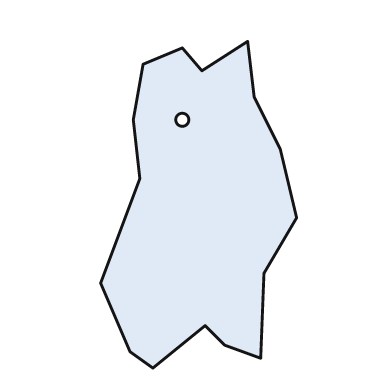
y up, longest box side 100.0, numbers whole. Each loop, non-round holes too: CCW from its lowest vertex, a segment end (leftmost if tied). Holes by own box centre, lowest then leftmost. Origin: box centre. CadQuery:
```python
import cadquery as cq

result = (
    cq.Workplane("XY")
    .moveTo(-14.0, -50.0)
    .lineTo(2.0, -37.0)
    .lineTo(8.0, -43.0)
    .lineTo(19.0, -47.0)
    .lineTo(20.0, -21.0)
    .lineTo(30.0, -4.0)
    .lineTo(25.0, 17.0)
    .lineTo(17.0, 33.0)
    .lineTo(15.0, 50.0)
    .lineTo(1.0, 41.0)
    .lineTo(-5.0, 48.0)
    .lineTo(-17.0, 43.0)
    .lineTo(-20.0, 26.0)
    .lineTo(-18.0, 8.0)
    .lineTo(-30.0, -24.0)
    .lineTo(-21.0, -45.0)
    .close()
    .moveTo(-5.0, 26.0)
    .circle(2.0)
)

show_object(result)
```